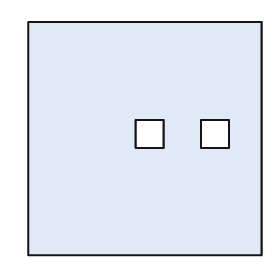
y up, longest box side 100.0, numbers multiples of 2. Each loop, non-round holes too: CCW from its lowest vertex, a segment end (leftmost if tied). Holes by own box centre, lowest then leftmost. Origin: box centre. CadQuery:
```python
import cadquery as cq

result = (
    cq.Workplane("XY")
    .moveTo(-50.0, -50.0)
    .lineTo(50.0, -50.0)
    .lineTo(50.0, 50.0)
    .lineTo(-50.0, 50.0)
    .close()
    .moveTo(-4.0, -4.0)
    .lineTo(8.0, -4.0)
    .lineTo(8.0, 8.0)
    .lineTo(-4.0, 8.0)
    .close()
    .moveTo(24.0, -4.0)
    .lineTo(36.0, -4.0)
    .lineTo(36.0, 8.0)
    .lineTo(24.0, 8.0)
    .close()
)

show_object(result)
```